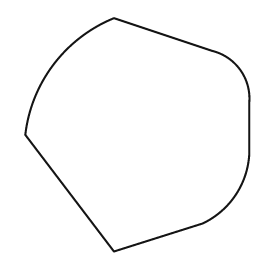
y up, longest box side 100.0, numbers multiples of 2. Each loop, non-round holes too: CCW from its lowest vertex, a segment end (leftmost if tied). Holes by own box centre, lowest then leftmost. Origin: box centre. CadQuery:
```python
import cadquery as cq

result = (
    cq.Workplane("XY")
    .moveTo(-10.0, -50.0)
    .lineTo(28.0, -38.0)
    .threePointArc((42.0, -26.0), (48.0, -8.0))
    .lineTo(48.0, 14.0)
    .threePointArc((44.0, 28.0), (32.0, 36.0))
    .lineTo(-10.0, 50.0)
    .threePointArc((-36.0, 30.0), (-48.0, 0.0))
    .close()
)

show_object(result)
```